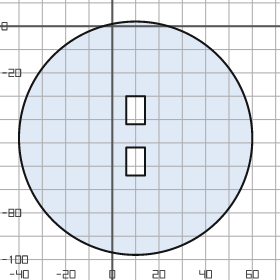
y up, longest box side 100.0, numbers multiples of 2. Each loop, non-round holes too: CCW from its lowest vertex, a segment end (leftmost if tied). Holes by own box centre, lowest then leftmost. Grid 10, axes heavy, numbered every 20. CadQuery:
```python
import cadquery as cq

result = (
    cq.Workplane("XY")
    .moveTo(10.0, -48.0)
    .circle(50.0)
    .moveTo(6.0, -64.0)
    .lineTo(14.0, -64.0)
    .lineTo(14.0, -52.0)
    .lineTo(6.0, -52.0)
    .close()
    .moveTo(6.0, -42.0)
    .lineTo(14.0, -42.0)
    .lineTo(14.0, -30.0)
    .lineTo(6.0, -30.0)
    .close()
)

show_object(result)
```